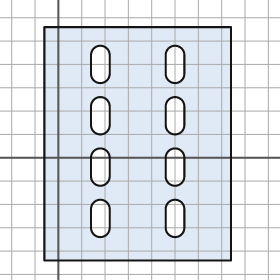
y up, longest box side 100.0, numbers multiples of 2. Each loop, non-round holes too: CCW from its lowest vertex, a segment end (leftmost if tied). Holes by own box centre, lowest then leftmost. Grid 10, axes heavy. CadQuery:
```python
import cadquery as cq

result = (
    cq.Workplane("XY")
    .moveTo(-6.0, -44.0)
    .lineTo(74.0, -44.0)
    .lineTo(74.0, 56.0)
    .lineTo(-6.0, 56.0)
    .close()
    .moveTo(14.0, -30.0)
    .threePointArc((18.0, -34.0), (22.0, -30.0))
    .lineTo(22.0, -22.0)
    .threePointArc((18.0, -18.0), (14.0, -22.0))
    .close()
    .moveTo(46.0, -30.0)
    .threePointArc((50.0, -34.0), (54.0, -30.0))
    .lineTo(54.0, -22.0)
    .threePointArc((50.0, -18.0), (46.0, -22.0))
    .close()
    .moveTo(14.0, -8.0)
    .threePointArc((18.0, -12.0), (22.0, -8.0))
    .lineTo(22.0, 0.0)
    .threePointArc((18.0, 4.0), (14.0, 0.0))
    .close()
    .moveTo(46.0, -8.0)
    .threePointArc((50.0, -12.0), (54.0, -8.0))
    .lineTo(54.0, 0.0)
    .threePointArc((50.0, 4.0), (46.0, 0.0))
    .close()
    .moveTo(14.0, 14.0)
    .threePointArc((18.0, 10.0), (22.0, 14.0))
    .lineTo(22.0, 22.0)
    .threePointArc((18.0, 26.0), (14.0, 22.0))
    .close()
    .moveTo(46.0, 14.0)
    .threePointArc((50.0, 10.0), (54.0, 14.0))
    .lineTo(54.0, 22.0)
    .threePointArc((50.0, 26.0), (46.0, 22.0))
    .close()
    .moveTo(14.0, 36.0)
    .threePointArc((18.0, 32.0), (22.0, 36.0))
    .lineTo(22.0, 44.0)
    .threePointArc((18.0, 48.0), (14.0, 44.0))
    .close()
    .moveTo(46.0, 36.0)
    .threePointArc((50.0, 32.0), (54.0, 36.0))
    .lineTo(54.0, 44.0)
    .threePointArc((50.0, 48.0), (46.0, 44.0))
    .close()
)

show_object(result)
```